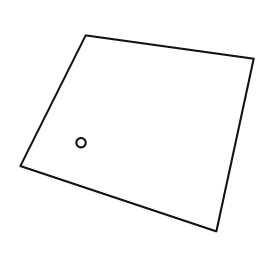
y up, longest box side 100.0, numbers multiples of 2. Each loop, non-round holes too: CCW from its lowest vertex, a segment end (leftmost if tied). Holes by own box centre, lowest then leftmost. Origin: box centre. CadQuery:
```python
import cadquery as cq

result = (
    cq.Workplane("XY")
    .moveTo(34.0, -42.0)
    .lineTo(50.0, 32.0)
    .lineTo(-22.0, 42.0)
    .lineTo(-50.0, -14.0)
    .close()
    .moveTo(-24.0, -4.0)
    .circle(2.0)
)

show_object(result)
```